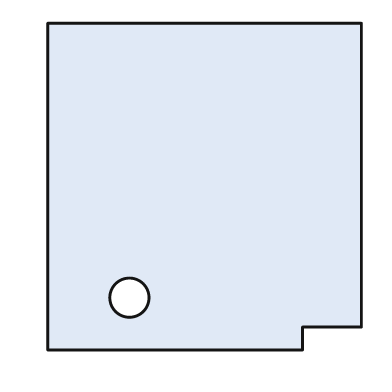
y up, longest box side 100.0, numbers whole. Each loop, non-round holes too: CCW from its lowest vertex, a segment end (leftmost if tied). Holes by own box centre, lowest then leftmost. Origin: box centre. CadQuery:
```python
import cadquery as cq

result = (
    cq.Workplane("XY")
    .moveTo(-48.0, -50.0)
    .lineTo(30.0, -50.0)
    .lineTo(30.0, -43.0)
    .lineTo(48.0, -43.0)
    .lineTo(48.0, 50.0)
    .lineTo(-48.0, 50.0)
    .close()
    .moveTo(-23.0, -34.0)
    .circle(6.0)
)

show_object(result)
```